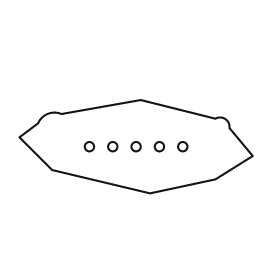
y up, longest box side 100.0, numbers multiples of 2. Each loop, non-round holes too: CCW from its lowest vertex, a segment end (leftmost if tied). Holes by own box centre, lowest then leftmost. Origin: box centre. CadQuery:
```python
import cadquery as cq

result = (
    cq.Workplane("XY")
    .moveTo(6.0, -20.0)
    .lineTo(34.0, -14.0)
    .lineTo(50.0, -4.0)
    .lineTo(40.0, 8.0)
    .threePointArc((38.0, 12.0), (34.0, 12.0))
    .lineTo(2.0, 20.0)
    .lineTo(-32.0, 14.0)
    .threePointArc((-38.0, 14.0), (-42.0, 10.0))
    .lineTo(-50.0, 4.0)
    .lineTo(-36.0, -10.0)
    .close()
    .moveTo(-20.0, 0.0)
    .circle(2.0)
    .moveTo(-10.0, 0.0)
    .circle(2.0)
    .moveTo(0.0, 0.0)
    .circle(2.0)
    .moveTo(10.0, 0.0)
    .circle(2.0)
    .moveTo(20.0, 0.0)
    .circle(2.0)
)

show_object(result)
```